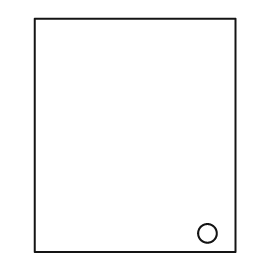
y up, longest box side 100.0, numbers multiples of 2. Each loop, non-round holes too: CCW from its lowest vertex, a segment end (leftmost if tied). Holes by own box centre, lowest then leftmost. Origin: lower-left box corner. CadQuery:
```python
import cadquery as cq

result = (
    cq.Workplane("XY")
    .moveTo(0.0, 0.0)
    .lineTo(86.0, 0.0)
    .lineTo(86.0, 100.0)
    .lineTo(0.0, 100.0)
    .close()
    .moveTo(74.0, 8.0)
    .circle(4.0)
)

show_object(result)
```